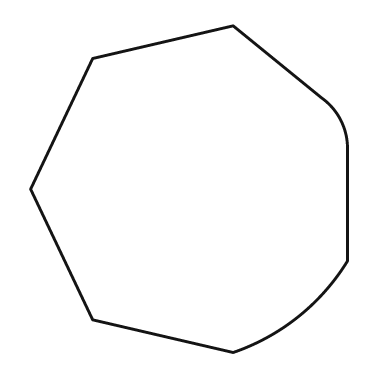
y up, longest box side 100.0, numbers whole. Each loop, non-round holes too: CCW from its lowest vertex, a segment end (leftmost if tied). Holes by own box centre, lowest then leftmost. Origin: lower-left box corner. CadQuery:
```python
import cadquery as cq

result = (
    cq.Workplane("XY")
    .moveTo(62.0, 0.0)
    .threePointArc((82.0, 11.0), (97.0, 28.0))
    .lineTo(97.0, 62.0)
    .threePointArc((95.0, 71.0), (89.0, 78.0))
    .lineTo(62.0, 100.0)
    .lineTo(19.0, 90.0)
    .lineTo(0.0, 50.0)
    .lineTo(19.0, 10.0)
    .close()
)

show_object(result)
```